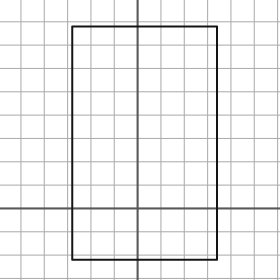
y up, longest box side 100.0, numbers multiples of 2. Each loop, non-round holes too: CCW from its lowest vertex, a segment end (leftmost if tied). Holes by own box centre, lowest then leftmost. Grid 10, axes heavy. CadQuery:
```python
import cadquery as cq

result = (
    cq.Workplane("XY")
    .moveTo(-28.0, -22.0)
    .lineTo(34.0, -22.0)
    .lineTo(34.0, 78.0)
    .lineTo(-28.0, 78.0)
    .close()
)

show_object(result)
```